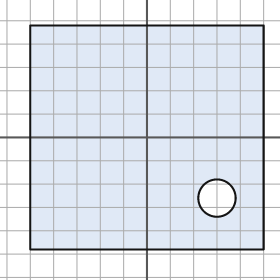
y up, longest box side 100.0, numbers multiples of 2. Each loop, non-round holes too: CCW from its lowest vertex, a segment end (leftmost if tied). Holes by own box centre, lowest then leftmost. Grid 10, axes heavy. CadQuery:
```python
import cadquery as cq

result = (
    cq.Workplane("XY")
    .moveTo(-50.0, -48.0)
    .lineTo(50.0, -48.0)
    .lineTo(50.0, 48.0)
    .lineTo(-50.0, 48.0)
    .close()
    .moveTo(30.0, -26.0)
    .circle(8.0)
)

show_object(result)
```